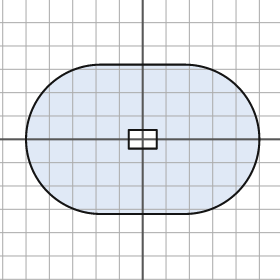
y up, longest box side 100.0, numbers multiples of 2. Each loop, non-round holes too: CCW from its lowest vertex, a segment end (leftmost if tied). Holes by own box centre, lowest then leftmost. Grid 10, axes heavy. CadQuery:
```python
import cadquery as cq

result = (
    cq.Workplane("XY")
    .moveTo(-18.0, -32.0)
    .lineTo(18.0, -32.0)
    .threePointArc((50.0, 0.0), (18.0, 32.0))
    .lineTo(-18.0, 32.0)
    .threePointArc((-50.0, 0.0), (-18.0, -32.0))
    .close()
    .moveTo(-6.0, -4.0)
    .lineTo(6.0, -4.0)
    .lineTo(6.0, 4.0)
    .lineTo(-6.0, 4.0)
    .close()
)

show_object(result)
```